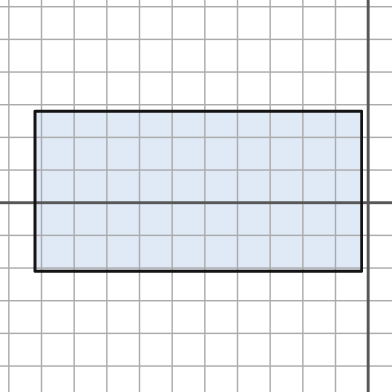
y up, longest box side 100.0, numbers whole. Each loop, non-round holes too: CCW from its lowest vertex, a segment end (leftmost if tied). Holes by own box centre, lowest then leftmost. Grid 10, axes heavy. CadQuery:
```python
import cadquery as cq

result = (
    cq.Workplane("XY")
    .moveTo(-102.0, -21.0)
    .lineTo(-2.0, -21.0)
    .lineTo(-2.0, 28.0)
    .lineTo(-102.0, 28.0)
    .close()
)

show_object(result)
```